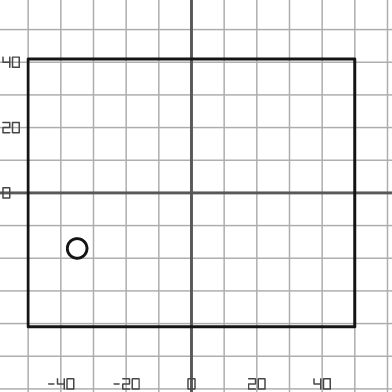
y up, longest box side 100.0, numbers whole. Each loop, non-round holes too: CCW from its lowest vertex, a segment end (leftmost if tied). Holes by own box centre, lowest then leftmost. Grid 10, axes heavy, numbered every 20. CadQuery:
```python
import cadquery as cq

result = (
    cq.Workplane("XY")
    .moveTo(-50.0, -41.0)
    .lineTo(50.0, -41.0)
    .lineTo(50.0, 41.0)
    .lineTo(-50.0, 41.0)
    .close()
    .moveTo(-35.0, -17.0)
    .circle(3.0)
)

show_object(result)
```